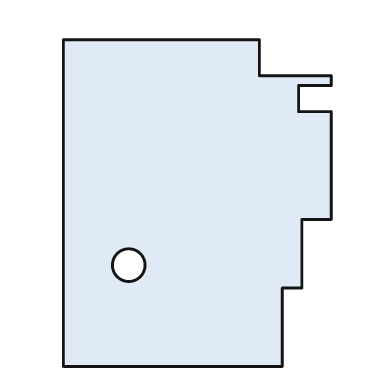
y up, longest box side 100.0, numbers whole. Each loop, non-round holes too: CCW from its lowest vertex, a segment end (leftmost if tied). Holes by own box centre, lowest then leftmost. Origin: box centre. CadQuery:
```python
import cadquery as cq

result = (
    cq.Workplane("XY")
    .moveTo(-41.0, -50.0)
    .lineTo(26.0, -50.0)
    .lineTo(26.0, -26.0)
    .lineTo(32.0, -26.0)
    .lineTo(32.0, -5.0)
    .lineTo(41.0, -5.0)
    .lineTo(41.0, 28.0)
    .lineTo(31.0, 28.0)
    .lineTo(31.0, 36.0)
    .lineTo(41.0, 36.0)
    .lineTo(41.0, 39.0)
    .lineTo(19.0, 39.0)
    .lineTo(19.0, 50.0)
    .lineTo(-41.0, 50.0)
    .close()
    .moveTo(-21.0, -19.0)
    .circle(5.0)
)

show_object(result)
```